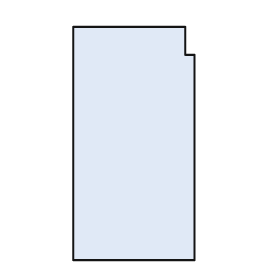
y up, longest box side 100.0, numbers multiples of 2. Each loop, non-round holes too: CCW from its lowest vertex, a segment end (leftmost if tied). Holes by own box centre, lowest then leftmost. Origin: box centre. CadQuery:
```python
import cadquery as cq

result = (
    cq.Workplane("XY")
    .moveTo(-26.0, -50.0)
    .lineTo(26.0, -50.0)
    .lineTo(26.0, 38.0)
    .lineTo(22.0, 38.0)
    .lineTo(22.0, 50.0)
    .lineTo(-26.0, 50.0)
    .close()
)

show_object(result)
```